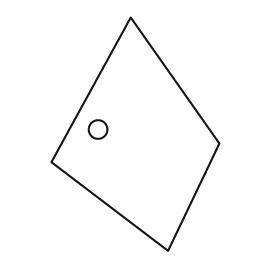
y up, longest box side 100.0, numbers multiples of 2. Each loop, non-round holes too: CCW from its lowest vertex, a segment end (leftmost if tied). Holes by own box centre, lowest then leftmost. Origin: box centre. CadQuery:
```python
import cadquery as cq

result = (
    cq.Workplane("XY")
    .moveTo(14.0, -50.0)
    .lineTo(36.0, -4.0)
    .lineTo(-2.0, 50.0)
    .lineTo(-36.0, -12.0)
    .close()
    .moveTo(-16.0, 2.0)
    .circle(4.0)
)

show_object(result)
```